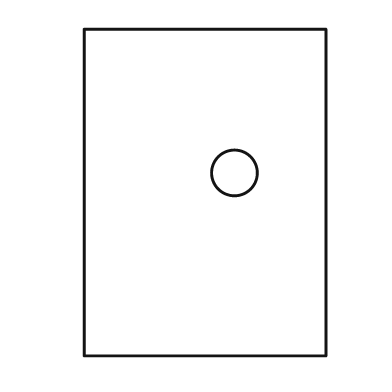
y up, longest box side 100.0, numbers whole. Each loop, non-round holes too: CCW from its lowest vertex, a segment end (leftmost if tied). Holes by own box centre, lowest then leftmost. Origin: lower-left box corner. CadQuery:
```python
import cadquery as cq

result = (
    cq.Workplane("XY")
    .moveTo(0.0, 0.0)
    .lineTo(74.0, 0.0)
    .lineTo(74.0, 100.0)
    .lineTo(0.0, 100.0)
    .close()
    .moveTo(46.0, 56.0)
    .circle(7.0)
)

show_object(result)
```